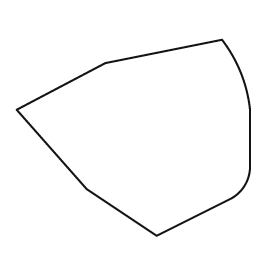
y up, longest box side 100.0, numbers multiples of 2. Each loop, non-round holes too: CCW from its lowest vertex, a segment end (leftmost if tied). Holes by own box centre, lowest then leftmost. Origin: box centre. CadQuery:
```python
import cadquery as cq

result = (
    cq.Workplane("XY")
    .moveTo(10.0, -42.0)
    .lineTo(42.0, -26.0)
    .threePointArc((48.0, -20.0), (50.0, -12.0))
    .lineTo(50.0, 12.0)
    .threePointArc((46.0, 28.0), (38.0, 42.0))
    .lineTo(-12.0, 32.0)
    .lineTo(-50.0, 12.0)
    .lineTo(-20.0, -22.0)
    .close()
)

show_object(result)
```